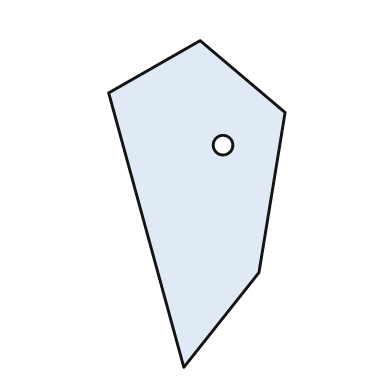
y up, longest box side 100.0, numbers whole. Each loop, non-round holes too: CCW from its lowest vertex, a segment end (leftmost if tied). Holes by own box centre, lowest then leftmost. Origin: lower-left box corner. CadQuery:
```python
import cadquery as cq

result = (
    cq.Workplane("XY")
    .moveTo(23.0, 0.0)
    .lineTo(46.0, 29.0)
    .lineTo(54.0, 78.0)
    .lineTo(28.0, 100.0)
    .lineTo(0.0, 84.0)
    .close()
    .moveTo(35.0, 68.0)
    .circle(3.0)
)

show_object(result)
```